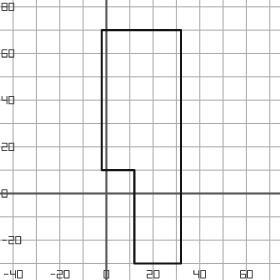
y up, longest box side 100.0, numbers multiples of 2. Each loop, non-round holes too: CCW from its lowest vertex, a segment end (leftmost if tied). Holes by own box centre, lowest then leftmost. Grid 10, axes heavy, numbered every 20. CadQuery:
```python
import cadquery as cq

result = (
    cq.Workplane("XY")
    .moveTo(12.0, -30.0)
    .lineTo(32.0, -30.0)
    .lineTo(32.0, 70.0)
    .lineTo(-2.0, 70.0)
    .lineTo(-2.0, 10.0)
    .lineTo(12.0, 10.0)
    .close()
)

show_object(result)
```